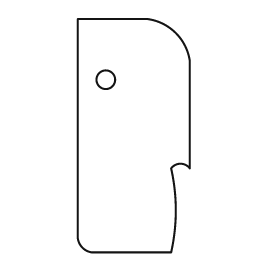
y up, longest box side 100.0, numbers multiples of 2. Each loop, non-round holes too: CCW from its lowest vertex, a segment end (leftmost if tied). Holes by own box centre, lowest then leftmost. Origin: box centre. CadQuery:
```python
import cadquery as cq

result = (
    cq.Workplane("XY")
    .moveTo(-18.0, -50.0)
    .lineTo(16.0, -50.0)
    .threePointArc((18.0, -32.0), (16.0, -14.0))
    .threePointArc((20.0, -12.0), (24.0, -14.0))
    .lineTo(24.0, 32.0)
    .threePointArc((18.0, 44.0), (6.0, 50.0))
    .lineTo(-24.0, 50.0)
    .lineTo(-24.0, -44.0)
    .threePointArc((-22.0, -48.0), (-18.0, -50.0))
    .close()
    .moveTo(-12.0, 24.0)
    .circle(4.0)
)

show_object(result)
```